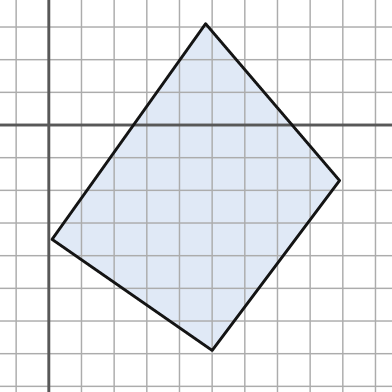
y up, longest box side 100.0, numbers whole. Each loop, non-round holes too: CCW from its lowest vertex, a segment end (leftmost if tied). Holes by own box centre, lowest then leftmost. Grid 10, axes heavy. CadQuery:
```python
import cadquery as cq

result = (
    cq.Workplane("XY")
    .moveTo(50.0, -69.0)
    .lineTo(89.0, -17.0)
    .lineTo(48.0, 31.0)
    .lineTo(1.0, -35.0)
    .close()
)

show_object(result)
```